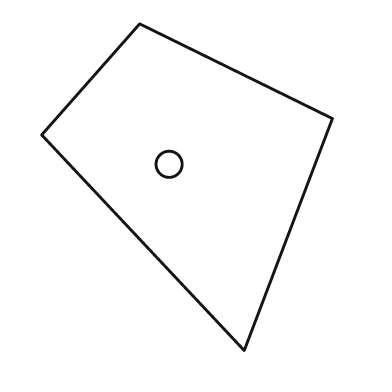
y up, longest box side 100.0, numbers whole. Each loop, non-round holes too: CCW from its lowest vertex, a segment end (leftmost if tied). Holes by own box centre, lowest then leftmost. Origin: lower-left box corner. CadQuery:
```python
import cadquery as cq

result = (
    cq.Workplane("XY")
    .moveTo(62.0, 0.0)
    .lineTo(89.0, 71.0)
    .lineTo(30.0, 100.0)
    .lineTo(0.0, 66.0)
    .close()
    .moveTo(39.0, 57.0)
    .circle(4.0)
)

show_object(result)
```